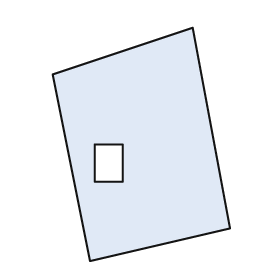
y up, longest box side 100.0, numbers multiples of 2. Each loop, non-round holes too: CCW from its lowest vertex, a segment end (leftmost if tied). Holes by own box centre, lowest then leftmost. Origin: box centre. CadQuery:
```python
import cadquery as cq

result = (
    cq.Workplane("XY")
    .moveTo(-22.0, -50.0)
    .lineTo(38.0, -36.0)
    .lineTo(22.0, 50.0)
    .lineTo(-38.0, 30.0)
    .close()
    .moveTo(-20.0, -16.0)
    .lineTo(-8.0, -16.0)
    .lineTo(-8.0, 0.0)
    .lineTo(-20.0, 0.0)
    .close()
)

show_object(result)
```